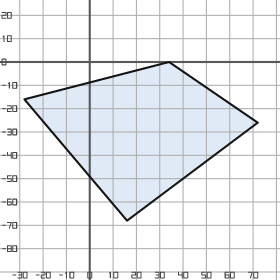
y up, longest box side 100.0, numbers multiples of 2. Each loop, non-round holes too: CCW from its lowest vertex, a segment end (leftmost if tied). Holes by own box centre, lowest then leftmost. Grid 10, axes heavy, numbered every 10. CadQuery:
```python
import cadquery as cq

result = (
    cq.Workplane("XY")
    .moveTo(16.0, -68.0)
    .lineTo(72.0, -26.0)
    .lineTo(34.0, 0.0)
    .lineTo(-28.0, -16.0)
    .close()
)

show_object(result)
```